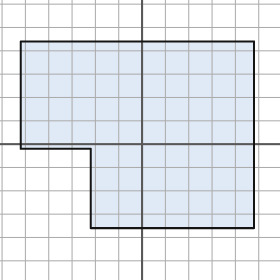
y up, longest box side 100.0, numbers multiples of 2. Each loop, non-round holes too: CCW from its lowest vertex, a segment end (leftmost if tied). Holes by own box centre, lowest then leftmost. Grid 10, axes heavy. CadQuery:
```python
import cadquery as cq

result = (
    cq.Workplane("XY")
    .moveTo(-22.0, -36.0)
    .lineTo(48.0, -36.0)
    .lineTo(48.0, 44.0)
    .lineTo(-52.0, 44.0)
    .lineTo(-52.0, -2.0)
    .lineTo(-22.0, -2.0)
    .close()
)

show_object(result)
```